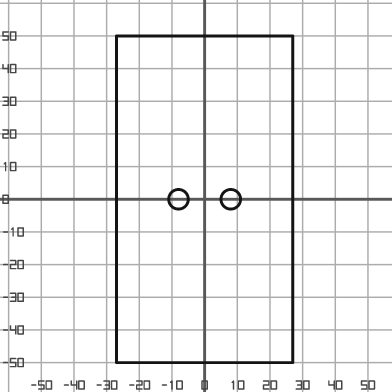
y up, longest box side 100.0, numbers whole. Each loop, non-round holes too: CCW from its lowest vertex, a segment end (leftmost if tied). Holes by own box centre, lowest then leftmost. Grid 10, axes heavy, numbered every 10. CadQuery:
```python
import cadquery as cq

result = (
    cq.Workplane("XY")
    .moveTo(-27.0, -50.0)
    .lineTo(27.0, -50.0)
    .lineTo(27.0, 50.0)
    .lineTo(-27.0, 50.0)
    .close()
    .moveTo(-8.0, 0.0)
    .circle(3.0)
    .moveTo(8.0, 0.0)
    .circle(3.0)
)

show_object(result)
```